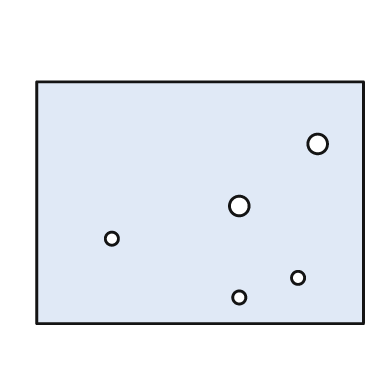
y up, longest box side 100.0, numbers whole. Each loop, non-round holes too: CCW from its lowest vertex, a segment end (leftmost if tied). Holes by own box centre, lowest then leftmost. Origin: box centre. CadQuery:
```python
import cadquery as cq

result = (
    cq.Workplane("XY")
    .moveTo(-50.0, -37.0)
    .lineTo(50.0, -37.0)
    .lineTo(50.0, 37.0)
    .lineTo(-50.0, 37.0)
    .close()
    .moveTo(12.0, -29.0)
    .circle(2.0)
    .moveTo(30.0, -23.0)
    .circle(2.0)
    .moveTo(-27.0, -11.0)
    .circle(2.0)
    .moveTo(12.0, -1.0)
    .circle(3.0)
    .moveTo(36.0, 18.0)
    .circle(3.0)
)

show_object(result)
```